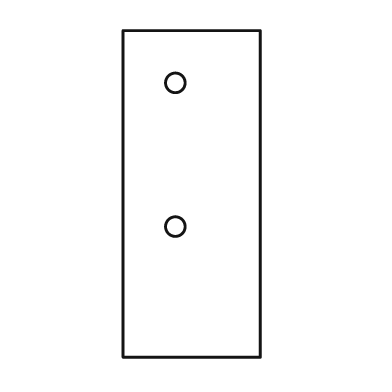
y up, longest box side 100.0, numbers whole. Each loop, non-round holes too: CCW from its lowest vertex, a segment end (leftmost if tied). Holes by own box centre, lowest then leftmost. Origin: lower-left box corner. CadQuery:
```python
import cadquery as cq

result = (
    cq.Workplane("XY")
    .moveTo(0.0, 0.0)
    .lineTo(42.0, 0.0)
    .lineTo(42.0, 100.0)
    .lineTo(0.0, 100.0)
    .close()
    .moveTo(16.0, 40.0)
    .circle(3.0)
    .moveTo(16.0, 84.0)
    .circle(3.0)
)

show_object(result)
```